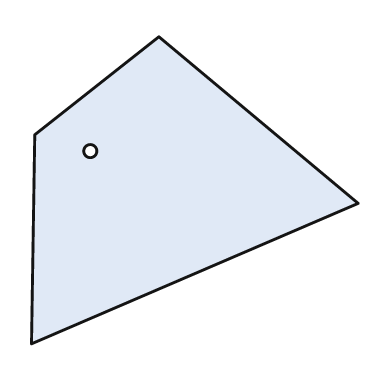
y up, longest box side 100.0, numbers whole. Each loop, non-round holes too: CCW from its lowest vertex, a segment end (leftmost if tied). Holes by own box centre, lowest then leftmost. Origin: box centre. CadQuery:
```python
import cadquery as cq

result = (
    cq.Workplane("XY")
    .moveTo(-50.0, -47.0)
    .lineTo(50.0, -4.0)
    .lineTo(-11.0, 47.0)
    .lineTo(-49.0, 17.0)
    .close()
    .moveTo(-32.0, 12.0)
    .circle(2.0)
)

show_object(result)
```